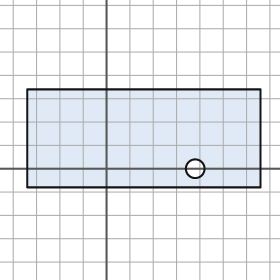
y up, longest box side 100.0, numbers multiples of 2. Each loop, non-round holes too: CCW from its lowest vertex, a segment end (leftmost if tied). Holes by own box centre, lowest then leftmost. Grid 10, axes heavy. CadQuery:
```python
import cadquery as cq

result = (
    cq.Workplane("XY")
    .moveTo(-34.0, -8.0)
    .lineTo(66.0, -8.0)
    .lineTo(66.0, 34.0)
    .lineTo(-34.0, 34.0)
    .close()
    .moveTo(38.0, 0.0)
    .circle(4.0)
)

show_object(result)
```